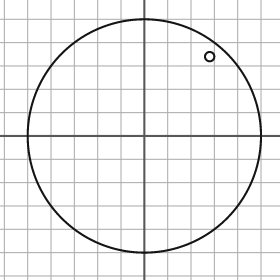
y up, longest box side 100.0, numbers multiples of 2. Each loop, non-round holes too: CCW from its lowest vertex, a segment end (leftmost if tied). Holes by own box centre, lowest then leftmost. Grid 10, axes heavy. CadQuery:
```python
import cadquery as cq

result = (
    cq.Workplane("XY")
    .moveTo(0.0, 0.0)
    .circle(50.0)
    .moveTo(28.0, 34.0)
    .circle(2.0)
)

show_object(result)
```